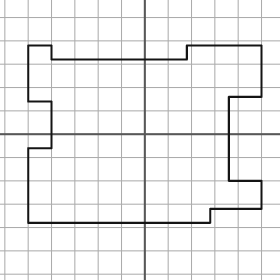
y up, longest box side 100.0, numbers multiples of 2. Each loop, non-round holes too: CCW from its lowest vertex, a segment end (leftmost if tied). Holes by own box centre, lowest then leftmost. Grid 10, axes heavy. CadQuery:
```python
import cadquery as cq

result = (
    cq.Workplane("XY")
    .moveTo(-50.0, -38.0)
    .lineTo(28.0, -38.0)
    .lineTo(28.0, -32.0)
    .lineTo(50.0, -32.0)
    .lineTo(50.0, -20.0)
    .lineTo(36.0, -20.0)
    .lineTo(36.0, 16.0)
    .lineTo(50.0, 16.0)
    .lineTo(50.0, 38.0)
    .lineTo(18.0, 38.0)
    .lineTo(18.0, 32.0)
    .lineTo(-40.0, 32.0)
    .lineTo(-40.0, 38.0)
    .lineTo(-50.0, 38.0)
    .lineTo(-50.0, 14.0)
    .lineTo(-40.0, 14.0)
    .lineTo(-40.0, -6.0)
    .lineTo(-50.0, -6.0)
    .close()
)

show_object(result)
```